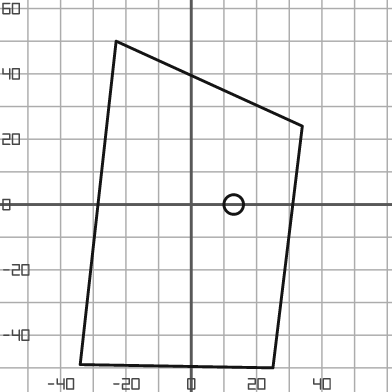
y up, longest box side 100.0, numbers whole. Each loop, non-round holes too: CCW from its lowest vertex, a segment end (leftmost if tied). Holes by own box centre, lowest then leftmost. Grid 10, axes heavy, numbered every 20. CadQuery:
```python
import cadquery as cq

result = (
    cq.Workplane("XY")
    .moveTo(25.0, -50.0)
    .lineTo(34.0, 24.0)
    .lineTo(-23.0, 50.0)
    .lineTo(-34.0, -49.0)
    .close()
    .moveTo(13.0, 0.0)
    .circle(3.0)
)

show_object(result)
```